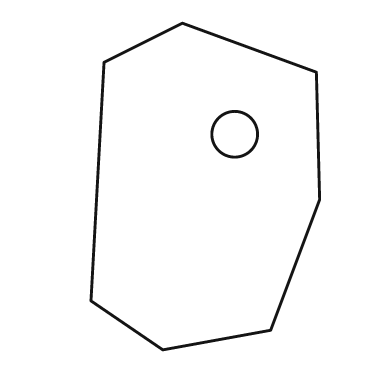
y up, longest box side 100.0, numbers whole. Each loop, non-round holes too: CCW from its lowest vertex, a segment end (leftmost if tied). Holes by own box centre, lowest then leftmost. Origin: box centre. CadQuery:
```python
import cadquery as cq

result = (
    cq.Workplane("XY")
    .moveTo(-13.0, -50.0)
    .lineTo(20.0, -44.0)
    .lineTo(35.0, -4.0)
    .lineTo(34.0, 35.0)
    .lineTo(-7.0, 50.0)
    .lineTo(-31.0, 38.0)
    .lineTo(-35.0, -35.0)
    .close()
    .moveTo(9.0, 16.0)
    .circle(7.0)
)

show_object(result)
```